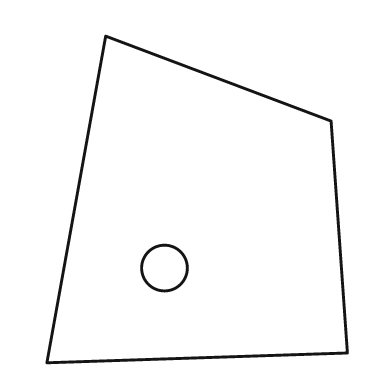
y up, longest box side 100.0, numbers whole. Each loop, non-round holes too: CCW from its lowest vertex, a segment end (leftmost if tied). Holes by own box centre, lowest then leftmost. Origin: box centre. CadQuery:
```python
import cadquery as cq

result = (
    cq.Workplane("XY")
    .moveTo(-46.0, -50.0)
    .lineTo(46.0, -47.0)
    .lineTo(41.0, 24.0)
    .lineTo(-28.0, 50.0)
    .close()
    .moveTo(-10.0, -21.0)
    .circle(7.0)
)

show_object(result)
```